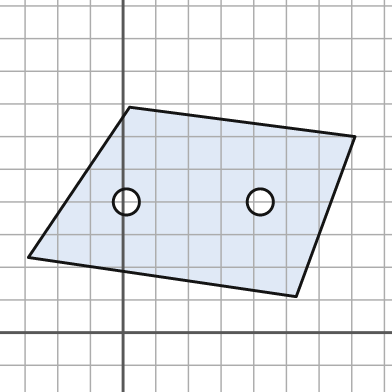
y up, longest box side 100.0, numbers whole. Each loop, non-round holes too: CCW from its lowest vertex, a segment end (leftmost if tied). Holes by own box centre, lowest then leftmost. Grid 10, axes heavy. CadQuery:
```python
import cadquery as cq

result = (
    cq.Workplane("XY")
    .moveTo(53.0, 11.0)
    .lineTo(71.0, 60.0)
    .lineTo(2.0, 69.0)
    .lineTo(-29.0, 23.0)
    .close()
    .moveTo(1.0, 40.0)
    .circle(4.0)
    .moveTo(42.0, 40.0)
    .circle(4.0)
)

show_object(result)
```